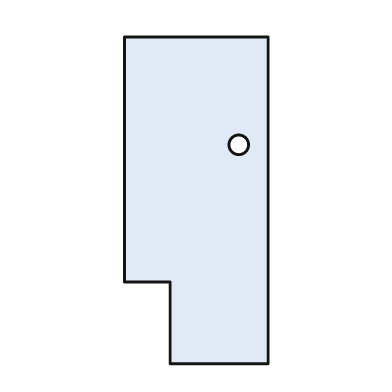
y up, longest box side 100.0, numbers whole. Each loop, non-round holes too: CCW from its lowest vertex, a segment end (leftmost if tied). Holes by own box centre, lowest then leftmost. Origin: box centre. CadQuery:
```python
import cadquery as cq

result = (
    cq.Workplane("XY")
    .moveTo(-8.0, -50.0)
    .lineTo(22.0, -50.0)
    .lineTo(22.0, 50.0)
    .lineTo(-22.0, 50.0)
    .lineTo(-22.0, -25.0)
    .lineTo(-8.0, -25.0)
    .close()
    .moveTo(13.0, 17.0)
    .circle(3.0)
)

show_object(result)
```